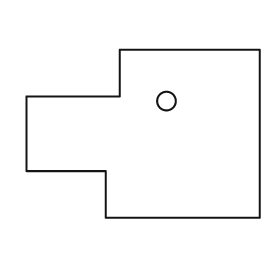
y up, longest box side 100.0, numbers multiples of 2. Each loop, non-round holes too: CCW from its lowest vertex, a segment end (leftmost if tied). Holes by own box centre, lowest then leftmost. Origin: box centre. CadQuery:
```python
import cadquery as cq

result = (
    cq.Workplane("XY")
    .moveTo(-16.0, -36.0)
    .lineTo(50.0, -36.0)
    .lineTo(50.0, 36.0)
    .lineTo(-10.0, 36.0)
    .lineTo(-10.0, 16.0)
    .lineTo(-50.0, 16.0)
    .lineTo(-50.0, -16.0)
    .lineTo(-16.0, -16.0)
    .close()
    .moveTo(10.0, 14.0)
    .circle(4.0)
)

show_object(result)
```